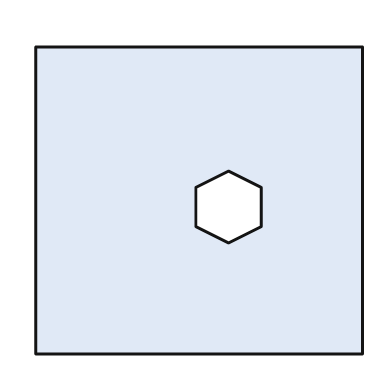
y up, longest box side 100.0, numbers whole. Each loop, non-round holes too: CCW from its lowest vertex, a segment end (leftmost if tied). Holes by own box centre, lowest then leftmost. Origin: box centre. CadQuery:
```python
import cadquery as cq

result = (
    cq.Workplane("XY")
    .moveTo(-50.0, -47.0)
    .lineTo(50.0, -47.0)
    .lineTo(50.0, 47.0)
    .lineTo(-50.0, 47.0)
    .close()
    .moveTo(9.0, -13.0)
    .lineTo(19.0, -8.0)
    .lineTo(19.0, 4.0)
    .lineTo(9.0, 9.0)
    .lineTo(-1.0, 4.0)
    .lineTo(-1.0, -8.0)
    .close()
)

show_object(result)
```